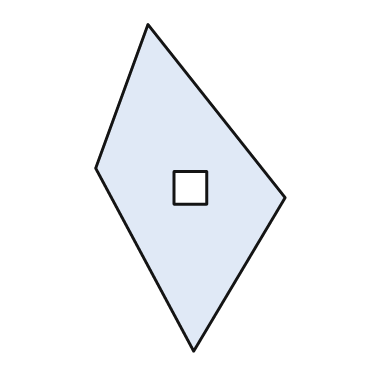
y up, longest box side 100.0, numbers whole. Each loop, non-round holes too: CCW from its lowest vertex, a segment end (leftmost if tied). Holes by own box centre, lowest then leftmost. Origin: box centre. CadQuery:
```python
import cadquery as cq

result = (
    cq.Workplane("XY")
    .moveTo(1.0, -50.0)
    .lineTo(29.0, -3.0)
    .lineTo(-13.0, 50.0)
    .lineTo(-29.0, 6.0)
    .close()
    .moveTo(-5.0, -5.0)
    .lineTo(5.0, -5.0)
    .lineTo(5.0, 5.0)
    .lineTo(-5.0, 5.0)
    .close()
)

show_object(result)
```